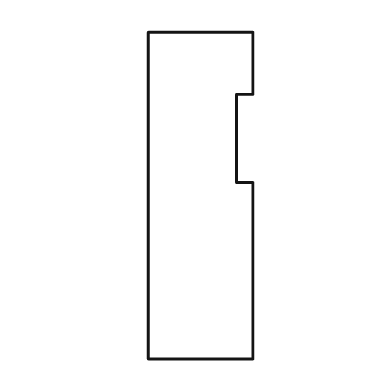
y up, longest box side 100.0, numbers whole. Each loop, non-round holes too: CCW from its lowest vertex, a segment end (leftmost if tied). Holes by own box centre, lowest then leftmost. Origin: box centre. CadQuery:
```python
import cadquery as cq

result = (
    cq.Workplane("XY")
    .moveTo(-16.0, -50.0)
    .lineTo(16.0, -50.0)
    .lineTo(16.0, 4.0)
    .lineTo(11.0, 4.0)
    .lineTo(11.0, 31.0)
    .lineTo(16.0, 31.0)
    .lineTo(16.0, 50.0)
    .lineTo(-16.0, 50.0)
    .close()
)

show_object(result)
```